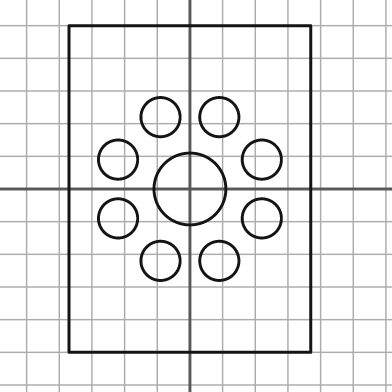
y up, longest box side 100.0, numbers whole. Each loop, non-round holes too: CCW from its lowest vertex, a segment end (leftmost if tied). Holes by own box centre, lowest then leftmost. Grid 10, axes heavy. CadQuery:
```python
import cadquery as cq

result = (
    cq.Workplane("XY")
    .moveTo(-37.0, -50.0)
    .lineTo(37.0, -50.0)
    .lineTo(37.0, 50.0)
    .lineTo(-37.0, 50.0)
    .close()
    .moveTo(-9.0, -22.0)
    .circle(6.0)
    .moveTo(9.0, -22.0)
    .circle(6.0)
    .moveTo(-22.0, -9.0)
    .circle(6.0)
    .moveTo(22.0, -9.0)
    .circle(6.0)
    .moveTo(0.0, 0.0)
    .circle(11.0)
    .moveTo(-22.0, 9.0)
    .circle(6.0)
    .moveTo(22.0, 9.0)
    .circle(6.0)
    .moveTo(-9.0, 22.0)
    .circle(6.0)
    .moveTo(9.0, 22.0)
    .circle(6.0)
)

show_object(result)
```